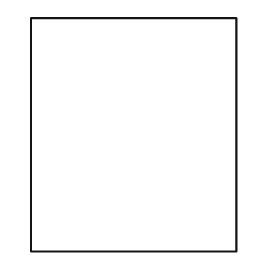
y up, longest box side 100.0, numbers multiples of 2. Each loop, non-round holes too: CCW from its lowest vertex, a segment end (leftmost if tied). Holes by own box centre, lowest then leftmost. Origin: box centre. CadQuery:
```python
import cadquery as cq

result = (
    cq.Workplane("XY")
    .moveTo(-44.0, -50.0)
    .lineTo(44.0, -50.0)
    .lineTo(44.0, 50.0)
    .lineTo(-44.0, 50.0)
    .close()
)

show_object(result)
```